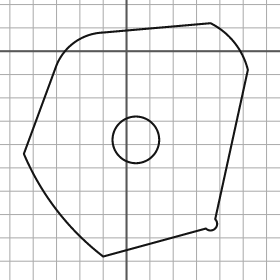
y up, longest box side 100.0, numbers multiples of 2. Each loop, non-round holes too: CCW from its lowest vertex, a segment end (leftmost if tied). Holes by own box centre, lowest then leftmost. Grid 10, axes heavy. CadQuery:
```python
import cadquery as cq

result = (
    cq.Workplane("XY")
    .moveTo(-10.0, -88.0)
    .lineTo(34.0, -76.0)
    .threePointArc((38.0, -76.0), (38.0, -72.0))
    .lineTo(52.0, -8.0)
    .threePointArc((46.0, 4.0), (36.0, 12.0))
    .lineTo(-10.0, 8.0)
    .threePointArc((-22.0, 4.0), (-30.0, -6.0))
    .lineTo(-44.0, -44.0)
    .threePointArc((-30.0, -68.0), (-10.0, -88.0))
    .close()
    .moveTo(4.0, -38.0)
    .circle(10.0)
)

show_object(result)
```